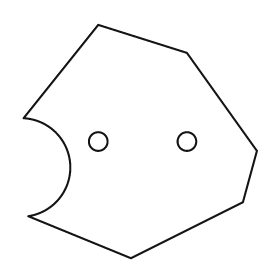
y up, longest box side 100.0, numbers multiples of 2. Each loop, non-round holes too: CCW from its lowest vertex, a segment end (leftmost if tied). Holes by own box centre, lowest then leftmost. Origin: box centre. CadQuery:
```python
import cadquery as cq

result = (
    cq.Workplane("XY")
    .moveTo(-4.0, -50.0)
    .lineTo(44.0, -26.0)
    .lineTo(50.0, -4.0)
    .lineTo(20.0, 38.0)
    .lineTo(-18.0, 50.0)
    .lineTo(-50.0, 10.0)
    .threePointArc((-30.0, -10.0), (-48.0, -32.0))
    .close()
    .moveTo(-18.0, 0.0)
    .circle(4.0)
    .moveTo(20.0, 0.0)
    .circle(4.0)
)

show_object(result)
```